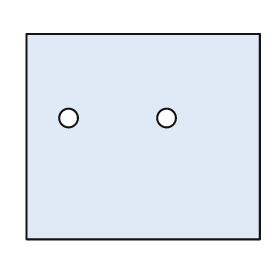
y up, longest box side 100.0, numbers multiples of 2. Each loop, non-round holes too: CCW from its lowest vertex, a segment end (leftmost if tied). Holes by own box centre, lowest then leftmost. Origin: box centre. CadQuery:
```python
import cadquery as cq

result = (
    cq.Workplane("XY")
    .moveTo(-50.0, -44.0)
    .lineTo(50.0, -44.0)
    .lineTo(50.0, 44.0)
    .lineTo(-50.0, 44.0)
    .close()
    .moveTo(-32.0, 8.0)
    .circle(4.0)
    .moveTo(10.0, 8.0)
    .circle(4.0)
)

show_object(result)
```